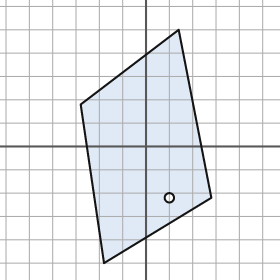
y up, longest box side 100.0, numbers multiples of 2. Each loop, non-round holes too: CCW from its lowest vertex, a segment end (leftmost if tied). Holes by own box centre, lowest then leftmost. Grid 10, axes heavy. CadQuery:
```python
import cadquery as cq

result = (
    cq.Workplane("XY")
    .moveTo(-18.0, -50.0)
    .lineTo(28.0, -22.0)
    .lineTo(14.0, 50.0)
    .lineTo(-28.0, 18.0)
    .close()
    .moveTo(10.0, -22.0)
    .circle(2.0)
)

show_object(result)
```